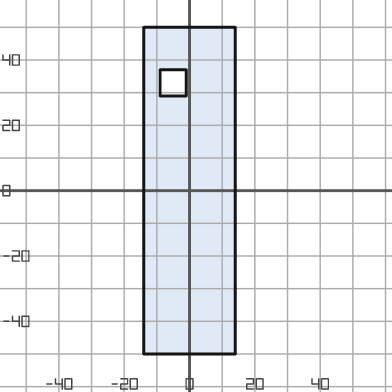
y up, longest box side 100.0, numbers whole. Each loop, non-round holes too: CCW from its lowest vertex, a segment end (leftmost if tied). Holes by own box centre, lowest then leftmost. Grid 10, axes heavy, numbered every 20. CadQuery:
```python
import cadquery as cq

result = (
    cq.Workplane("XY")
    .moveTo(-14.0, -50.0)
    .lineTo(14.0, -50.0)
    .lineTo(14.0, 50.0)
    .lineTo(-14.0, 50.0)
    .close()
    .moveTo(-9.0, 29.0)
    .lineTo(-1.0, 29.0)
    .lineTo(-1.0, 37.0)
    .lineTo(-9.0, 37.0)
    .close()
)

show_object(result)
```